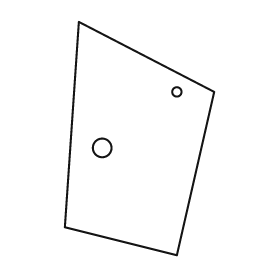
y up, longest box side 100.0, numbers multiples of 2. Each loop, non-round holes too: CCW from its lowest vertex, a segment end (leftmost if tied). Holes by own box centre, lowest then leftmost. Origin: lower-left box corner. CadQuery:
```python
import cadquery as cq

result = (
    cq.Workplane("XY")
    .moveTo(48.0, 0.0)
    .lineTo(64.0, 70.0)
    .lineTo(6.0, 100.0)
    .lineTo(0.0, 12.0)
    .close()
    .moveTo(16.0, 46.0)
    .circle(4.0)
    .moveTo(48.0, 70.0)
    .circle(2.0)
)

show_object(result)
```